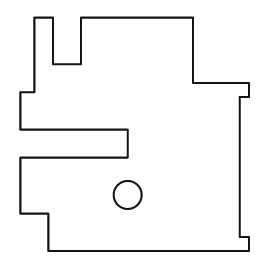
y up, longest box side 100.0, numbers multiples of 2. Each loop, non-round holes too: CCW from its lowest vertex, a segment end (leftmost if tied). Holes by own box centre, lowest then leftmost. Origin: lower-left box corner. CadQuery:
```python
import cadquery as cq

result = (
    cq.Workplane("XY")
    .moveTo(12.0, 0.0)
    .lineTo(98.0, 0.0)
    .lineTo(98.0, 6.0)
    .lineTo(94.0, 6.0)
    .lineTo(94.0, 66.0)
    .lineTo(98.0, 66.0)
    .lineTo(98.0, 72.0)
    .lineTo(74.0, 72.0)
    .lineTo(74.0, 100.0)
    .lineTo(26.0, 100.0)
    .lineTo(26.0, 80.0)
    .lineTo(14.0, 80.0)
    .lineTo(14.0, 100.0)
    .lineTo(6.0, 100.0)
    .lineTo(6.0, 68.0)
    .lineTo(0.0, 68.0)
    .lineTo(0.0, 52.0)
    .lineTo(46.0, 52.0)
    .lineTo(46.0, 40.0)
    .lineTo(0.0, 40.0)
    .lineTo(0.0, 16.0)
    .lineTo(12.0, 16.0)
    .close()
    .moveTo(46.0, 24.0)
    .circle(6.0)
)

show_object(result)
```